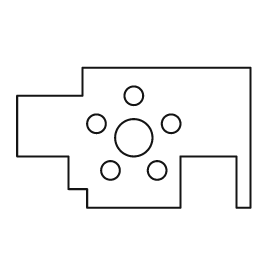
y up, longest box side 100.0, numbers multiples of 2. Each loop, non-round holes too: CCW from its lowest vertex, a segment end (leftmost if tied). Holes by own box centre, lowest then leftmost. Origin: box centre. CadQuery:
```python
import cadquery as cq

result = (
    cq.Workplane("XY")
    .moveTo(-20.0, -30.0)
    .lineTo(20.0, -30.0)
    .lineTo(20.0, -8.0)
    .lineTo(44.0, -8.0)
    .lineTo(44.0, -30.0)
    .lineTo(50.0, -30.0)
    .lineTo(50.0, 30.0)
    .lineTo(-22.0, 30.0)
    .lineTo(-22.0, 18.0)
    .lineTo(-50.0, 18.0)
    .lineTo(-50.0, -8.0)
    .lineTo(-28.0, -8.0)
    .lineTo(-28.0, -22.0)
    .lineTo(-20.0, -22.0)
    .close()
    .moveTo(-10.0, -14.0)
    .circle(4.0)
    .moveTo(10.0, -14.0)
    .circle(4.0)
    .moveTo(0.0, 0.0)
    .circle(8.0)
    .moveTo(-16.0, 6.0)
    .circle(4.0)
    .moveTo(16.0, 6.0)
    .circle(4.0)
    .moveTo(0.0, 18.0)
    .circle(4.0)
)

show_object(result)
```